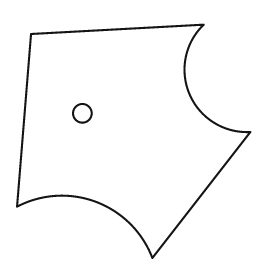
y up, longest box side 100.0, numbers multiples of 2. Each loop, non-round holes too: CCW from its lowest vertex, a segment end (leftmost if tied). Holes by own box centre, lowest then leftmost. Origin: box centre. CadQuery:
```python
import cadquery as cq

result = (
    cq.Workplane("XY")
    .moveTo(8.0, -50.0)
    .lineTo(50.0, 4.0)
    .threePointArc((24.0, 20.0), (30.0, 50.0))
    .lineTo(-44.0, 46.0)
    .lineTo(-50.0, -28.0)
    .threePointArc((-16.0, -26.0), (8.0, -50.0))
    .close()
    .moveTo(-22.0, 12.0)
    .circle(4.0)
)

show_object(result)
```